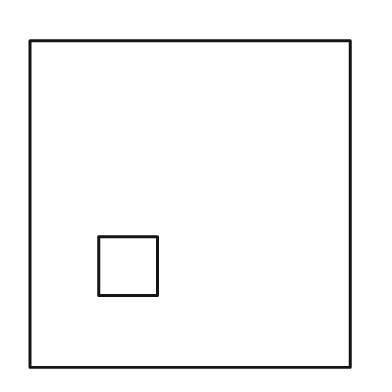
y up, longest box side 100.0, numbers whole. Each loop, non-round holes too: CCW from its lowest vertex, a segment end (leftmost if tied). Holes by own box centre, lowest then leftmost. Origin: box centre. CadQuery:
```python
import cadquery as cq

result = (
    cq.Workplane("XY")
    .moveTo(-49.0, -50.0)
    .lineTo(49.0, -50.0)
    .lineTo(49.0, 50.0)
    .lineTo(-49.0, 50.0)
    .close()
    .moveTo(-28.0, -28.0)
    .lineTo(-10.0, -28.0)
    .lineTo(-10.0, -10.0)
    .lineTo(-28.0, -10.0)
    .close()
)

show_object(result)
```